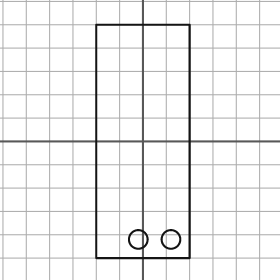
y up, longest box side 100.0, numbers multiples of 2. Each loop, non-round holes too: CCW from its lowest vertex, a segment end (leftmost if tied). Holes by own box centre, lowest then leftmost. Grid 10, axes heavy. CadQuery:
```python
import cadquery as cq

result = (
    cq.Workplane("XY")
    .moveTo(-20.0, -50.0)
    .lineTo(20.0, -50.0)
    .lineTo(20.0, 50.0)
    .lineTo(-20.0, 50.0)
    .close()
    .moveTo(-2.0, -42.0)
    .circle(4.0)
    .moveTo(12.0, -42.0)
    .circle(4.0)
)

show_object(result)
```